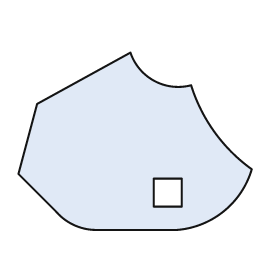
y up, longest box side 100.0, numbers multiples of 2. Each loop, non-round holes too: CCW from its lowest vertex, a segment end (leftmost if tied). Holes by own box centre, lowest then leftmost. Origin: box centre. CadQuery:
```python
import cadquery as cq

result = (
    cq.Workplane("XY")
    .moveTo(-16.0, -38.0)
    .lineTo(18.0, -38.0)
    .threePointArc((38.0, -30.0), (50.0, -12.0))
    .threePointArc((34.0, 4.0), (24.0, 24.0))
    .threePointArc((8.0, 26.0), (-2.0, 38.0))
    .lineTo(-42.0, 16.0)
    .lineTo(-50.0, -14.0)
    .lineTo(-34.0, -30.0)
    .threePointArc((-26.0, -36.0), (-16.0, -38.0))
    .close()
    .moveTo(8.0, -28.0)
    .lineTo(20.0, -28.0)
    .lineTo(20.0, -16.0)
    .lineTo(8.0, -16.0)
    .close()
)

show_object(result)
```